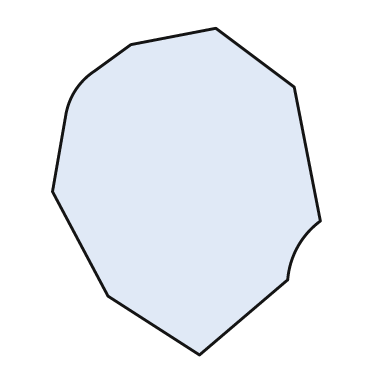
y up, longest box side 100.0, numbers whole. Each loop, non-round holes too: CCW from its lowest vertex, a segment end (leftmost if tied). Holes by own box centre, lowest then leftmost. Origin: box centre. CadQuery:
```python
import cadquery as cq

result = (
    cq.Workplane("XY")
    .moveTo(4.0, -50.0)
    .lineTo(31.0, -27.0)
    .threePointArc((34.0, -17.0), (41.0, -9.0))
    .lineTo(33.0, 32.0)
    .lineTo(9.0, 50.0)
    .lineTo(-17.0, 45.0)
    .lineTo(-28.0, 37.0)
    .threePointArc((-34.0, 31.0), (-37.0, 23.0))
    .lineTo(-41.0, 0.0)
    .lineTo(-24.0, -32.0)
    .close()
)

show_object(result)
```